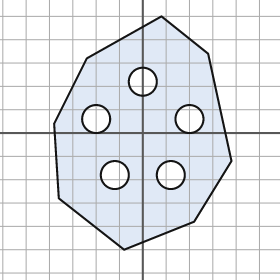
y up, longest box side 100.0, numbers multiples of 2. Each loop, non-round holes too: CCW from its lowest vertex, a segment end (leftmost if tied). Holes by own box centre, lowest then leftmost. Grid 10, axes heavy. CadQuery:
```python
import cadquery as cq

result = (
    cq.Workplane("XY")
    .moveTo(-8.0, -50.0)
    .lineTo(22.0, -38.0)
    .lineTo(38.0, -12.0)
    .lineTo(28.0, 34.0)
    .lineTo(8.0, 50.0)
    .lineTo(-24.0, 32.0)
    .lineTo(-38.0, 4.0)
    .lineTo(-36.0, -28.0)
    .close()
    .moveTo(-12.0, -18.0)
    .circle(6.0)
    .moveTo(12.0, -18.0)
    .circle(6.0)
    .moveTo(-20.0, 6.0)
    .circle(6.0)
    .moveTo(20.0, 6.0)
    .circle(6.0)
    .moveTo(0.0, 22.0)
    .circle(6.0)
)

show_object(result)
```